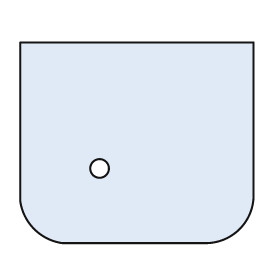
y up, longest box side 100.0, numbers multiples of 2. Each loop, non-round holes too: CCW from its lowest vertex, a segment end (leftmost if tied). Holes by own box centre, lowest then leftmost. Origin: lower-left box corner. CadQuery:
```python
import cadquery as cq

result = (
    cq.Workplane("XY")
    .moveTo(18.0, 0.0)
    .lineTo(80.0, 0.0)
    .threePointArc((94.0, 6.0), (100.0, 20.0))
    .lineTo(100.0, 86.0)
    .lineTo(0.0, 86.0)
    .lineTo(0.0, 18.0)
    .threePointArc((6.0, 6.0), (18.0, 0.0))
    .close()
    .moveTo(34.0, 32.0)
    .circle(4.0)
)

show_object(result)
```